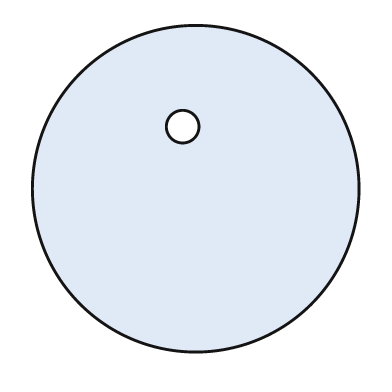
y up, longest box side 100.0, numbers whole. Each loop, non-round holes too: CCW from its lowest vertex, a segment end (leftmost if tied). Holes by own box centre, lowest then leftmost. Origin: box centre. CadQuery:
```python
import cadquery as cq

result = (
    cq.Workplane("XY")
    .moveTo(0.0, 0.0)
    .circle(50.0)
    .moveTo(-4.0, 19.0)
    .circle(5.0)
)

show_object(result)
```